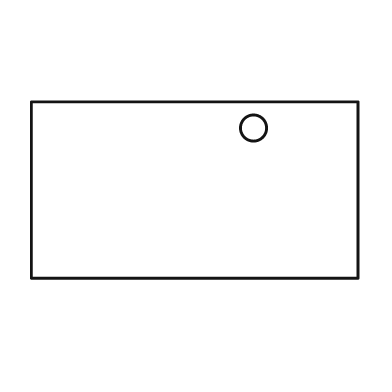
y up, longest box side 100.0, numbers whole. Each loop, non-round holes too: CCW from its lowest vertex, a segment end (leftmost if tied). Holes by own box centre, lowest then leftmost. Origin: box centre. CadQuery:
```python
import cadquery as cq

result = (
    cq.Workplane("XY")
    .moveTo(-50.0, -27.0)
    .lineTo(50.0, -27.0)
    .lineTo(50.0, 27.0)
    .lineTo(-50.0, 27.0)
    .close()
    .moveTo(18.0, 19.0)
    .circle(4.0)
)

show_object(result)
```